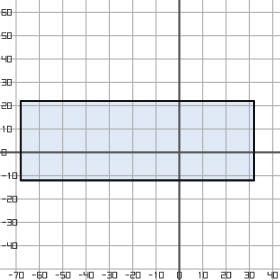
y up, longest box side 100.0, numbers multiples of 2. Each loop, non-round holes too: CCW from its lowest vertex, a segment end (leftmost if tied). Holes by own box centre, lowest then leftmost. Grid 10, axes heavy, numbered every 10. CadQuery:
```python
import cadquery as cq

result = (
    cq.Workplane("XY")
    .moveTo(-68.0, -12.0)
    .lineTo(32.0, -12.0)
    .lineTo(32.0, 22.0)
    .lineTo(-68.0, 22.0)
    .close()
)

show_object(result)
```